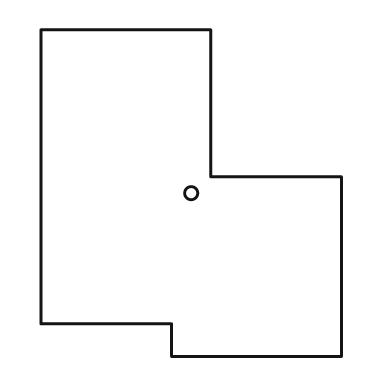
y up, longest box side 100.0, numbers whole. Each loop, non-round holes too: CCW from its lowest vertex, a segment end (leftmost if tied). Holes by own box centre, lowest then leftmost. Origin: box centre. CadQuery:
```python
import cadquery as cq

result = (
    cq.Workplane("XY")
    .moveTo(-6.0, -50.0)
    .lineTo(46.0, -50.0)
    .lineTo(46.0, 5.0)
    .lineTo(6.0, 5.0)
    .lineTo(6.0, 50.0)
    .lineTo(-46.0, 50.0)
    .lineTo(-46.0, -40.0)
    .lineTo(-6.0, -40.0)
    .close()
    .moveTo(0.0, 0.0)
    .circle(2.0)
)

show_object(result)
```